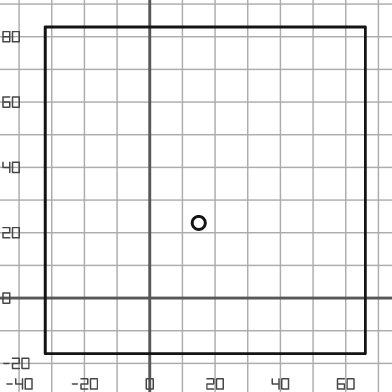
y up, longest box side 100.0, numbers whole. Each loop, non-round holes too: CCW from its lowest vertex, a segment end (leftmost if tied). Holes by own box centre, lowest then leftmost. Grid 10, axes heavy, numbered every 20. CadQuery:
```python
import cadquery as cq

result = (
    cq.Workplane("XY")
    .moveTo(-32.0, -17.0)
    .lineTo(66.0, -17.0)
    .lineTo(66.0, 83.0)
    .lineTo(-32.0, 83.0)
    .close()
    .moveTo(15.0, 23.0)
    .circle(2.0)
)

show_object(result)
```